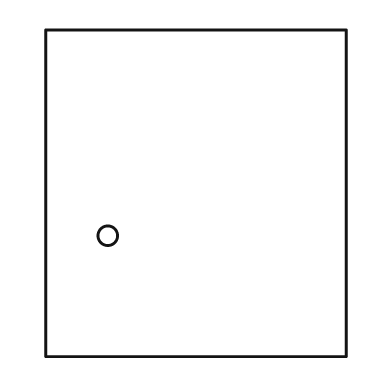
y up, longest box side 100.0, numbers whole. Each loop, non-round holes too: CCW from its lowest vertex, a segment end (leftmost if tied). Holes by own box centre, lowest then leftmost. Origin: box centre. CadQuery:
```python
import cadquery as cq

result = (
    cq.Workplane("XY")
    .moveTo(-46.0, -50.0)
    .lineTo(46.0, -50.0)
    .lineTo(46.0, 50.0)
    .lineTo(-46.0, 50.0)
    .close()
    .moveTo(-27.0, -13.0)
    .circle(3.0)
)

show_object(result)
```